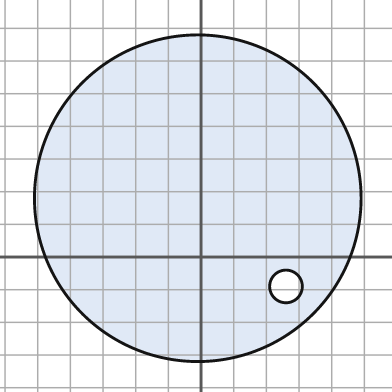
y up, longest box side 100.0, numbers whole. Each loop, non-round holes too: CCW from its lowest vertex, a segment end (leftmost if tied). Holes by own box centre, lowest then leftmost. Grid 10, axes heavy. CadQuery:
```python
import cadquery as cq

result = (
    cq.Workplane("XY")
    .moveTo(-1.0, 18.0)
    .circle(50.0)
    .moveTo(26.0, -9.0)
    .circle(5.0)
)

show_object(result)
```